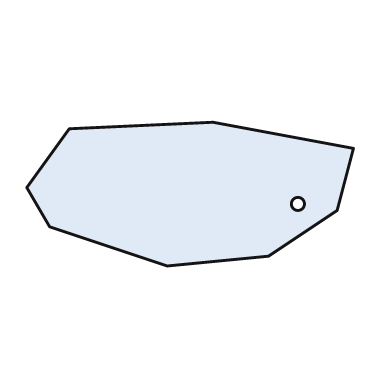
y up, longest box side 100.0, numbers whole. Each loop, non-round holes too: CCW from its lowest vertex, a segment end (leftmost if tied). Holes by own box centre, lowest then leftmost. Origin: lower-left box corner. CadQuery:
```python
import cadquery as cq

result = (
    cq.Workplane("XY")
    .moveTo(43.0, 0.0)
    .lineTo(74.0, 3.0)
    .lineTo(95.0, 17.0)
    .lineTo(100.0, 36.0)
    .lineTo(57.0, 44.0)
    .lineTo(13.0, 42.0)
    .lineTo(0.0, 24.0)
    .lineTo(7.0, 12.0)
    .close()
    .moveTo(83.0, 19.0)
    .circle(2.0)
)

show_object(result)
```